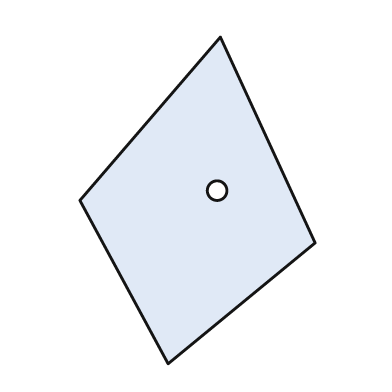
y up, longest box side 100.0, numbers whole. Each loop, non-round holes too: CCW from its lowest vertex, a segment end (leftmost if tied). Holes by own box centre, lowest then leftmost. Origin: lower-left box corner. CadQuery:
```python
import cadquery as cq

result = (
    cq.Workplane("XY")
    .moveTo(27.0, 0.0)
    .lineTo(72.0, 37.0)
    .lineTo(43.0, 100.0)
    .lineTo(0.0, 50.0)
    .close()
    .moveTo(42.0, 53.0)
    .circle(3.0)
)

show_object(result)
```